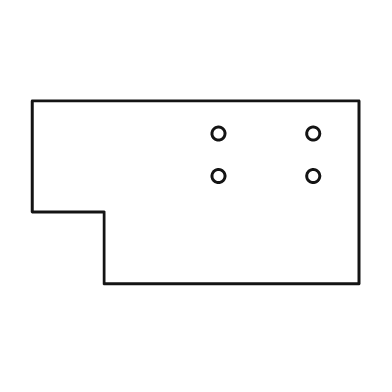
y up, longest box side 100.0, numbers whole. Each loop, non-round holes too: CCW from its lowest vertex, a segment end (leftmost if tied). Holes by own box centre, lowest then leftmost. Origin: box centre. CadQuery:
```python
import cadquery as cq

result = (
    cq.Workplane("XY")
    .moveTo(-28.0, -28.0)
    .lineTo(50.0, -28.0)
    .lineTo(50.0, 28.0)
    .lineTo(-50.0, 28.0)
    .lineTo(-50.0, -6.0)
    .lineTo(-28.0, -6.0)
    .close()
    .moveTo(7.0, 5.0)
    .circle(2.0)
    .moveTo(36.0, 5.0)
    .circle(2.0)
    .moveTo(7.0, 18.0)
    .circle(2.0)
    .moveTo(36.0, 18.0)
    .circle(2.0)
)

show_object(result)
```